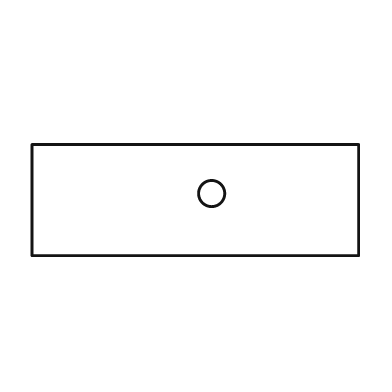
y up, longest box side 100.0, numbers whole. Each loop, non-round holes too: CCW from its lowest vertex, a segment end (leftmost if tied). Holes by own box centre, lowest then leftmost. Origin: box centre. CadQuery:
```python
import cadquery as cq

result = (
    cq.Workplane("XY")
    .moveTo(-50.0, -17.0)
    .lineTo(50.0, -17.0)
    .lineTo(50.0, 17.0)
    .lineTo(-50.0, 17.0)
    .close()
    .moveTo(5.0, 2.0)
    .circle(4.0)
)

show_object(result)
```